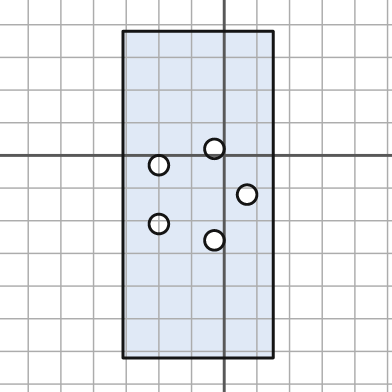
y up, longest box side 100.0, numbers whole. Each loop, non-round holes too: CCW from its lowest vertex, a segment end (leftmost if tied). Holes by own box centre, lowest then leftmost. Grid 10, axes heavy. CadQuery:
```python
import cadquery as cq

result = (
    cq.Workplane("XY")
    .moveTo(-31.0, -62.0)
    .lineTo(15.0, -62.0)
    .lineTo(15.0, 38.0)
    .lineTo(-31.0, 38.0)
    .close()
    .moveTo(-3.0, -26.0)
    .circle(3.0)
    .moveTo(-20.0, -21.0)
    .circle(3.0)
    .moveTo(7.0, -12.0)
    .circle(3.0)
    .moveTo(-20.0, -3.0)
    .circle(3.0)
    .moveTo(-3.0, 2.0)
    .circle(3.0)
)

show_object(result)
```